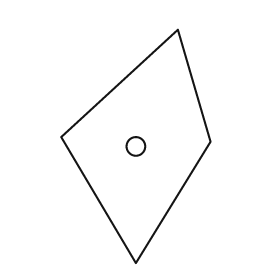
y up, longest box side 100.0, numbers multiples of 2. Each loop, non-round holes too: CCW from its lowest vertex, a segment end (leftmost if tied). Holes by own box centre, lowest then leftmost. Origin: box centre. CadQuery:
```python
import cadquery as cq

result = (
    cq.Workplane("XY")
    .moveTo(0.0, -50.0)
    .lineTo(32.0, 2.0)
    .lineTo(18.0, 50.0)
    .lineTo(-32.0, 4.0)
    .close()
    .moveTo(0.0, 0.0)
    .circle(4.0)
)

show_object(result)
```